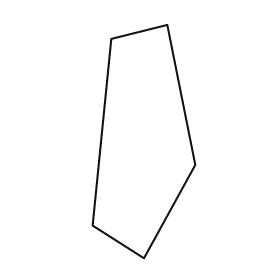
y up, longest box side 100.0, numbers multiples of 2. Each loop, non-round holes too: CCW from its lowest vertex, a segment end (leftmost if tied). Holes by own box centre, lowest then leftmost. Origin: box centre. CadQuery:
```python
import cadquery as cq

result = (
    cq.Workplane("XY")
    .moveTo(0.0, -50.0)
    .lineTo(22.0, -10.0)
    .lineTo(10.0, 50.0)
    .lineTo(-14.0, 44.0)
    .lineTo(-22.0, -36.0)
    .close()
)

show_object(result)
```